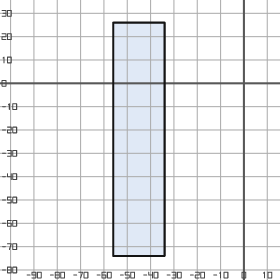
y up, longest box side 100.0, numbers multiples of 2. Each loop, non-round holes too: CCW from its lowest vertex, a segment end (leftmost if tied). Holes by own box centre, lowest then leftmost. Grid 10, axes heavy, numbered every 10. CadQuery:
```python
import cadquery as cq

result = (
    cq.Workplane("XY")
    .moveTo(-56.0, -74.0)
    .lineTo(-34.0, -74.0)
    .lineTo(-34.0, 26.0)
    .lineTo(-56.0, 26.0)
    .close()
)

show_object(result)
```